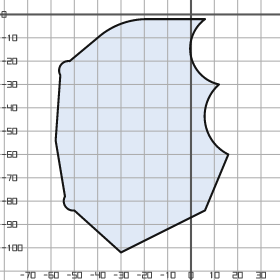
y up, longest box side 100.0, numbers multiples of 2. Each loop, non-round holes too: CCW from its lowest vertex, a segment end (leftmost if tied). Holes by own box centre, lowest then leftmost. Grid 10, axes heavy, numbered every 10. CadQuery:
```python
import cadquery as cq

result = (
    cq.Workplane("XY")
    .moveTo(-30.0, -102.0)
    .lineTo(6.0, -84.0)
    .lineTo(16.0, -60.0)
    .threePointArc((6.0, -46.0), (12.0, -30.0))
    .threePointArc((0.0, -18.0), (6.0, -2.0))
    .lineTo(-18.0, -2.0)
    .threePointArc((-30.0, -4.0), (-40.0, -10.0))
    .lineTo(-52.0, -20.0)
    .threePointArc((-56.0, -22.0), (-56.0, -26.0))
    .lineTo(-58.0, -54.0)
    .lineTo(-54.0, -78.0)
    .threePointArc((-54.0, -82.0), (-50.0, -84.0))
    .close()
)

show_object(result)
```